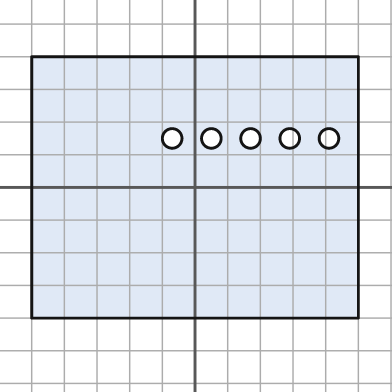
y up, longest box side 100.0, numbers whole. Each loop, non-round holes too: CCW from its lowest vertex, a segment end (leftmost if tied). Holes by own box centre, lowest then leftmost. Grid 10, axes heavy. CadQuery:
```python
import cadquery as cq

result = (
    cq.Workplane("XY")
    .moveTo(-50.0, -40.0)
    .lineTo(50.0, -40.0)
    .lineTo(50.0, 40.0)
    .lineTo(-50.0, 40.0)
    .close()
    .moveTo(-7.0, 15.0)
    .circle(3.0)
    .moveTo(5.0, 15.0)
    .circle(3.0)
    .moveTo(17.0, 15.0)
    .circle(3.0)
    .moveTo(29.0, 15.0)
    .circle(3.0)
    .moveTo(41.0, 15.0)
    .circle(3.0)
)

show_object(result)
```